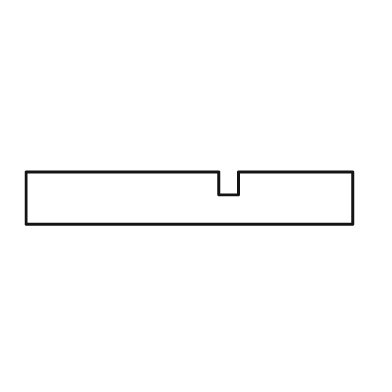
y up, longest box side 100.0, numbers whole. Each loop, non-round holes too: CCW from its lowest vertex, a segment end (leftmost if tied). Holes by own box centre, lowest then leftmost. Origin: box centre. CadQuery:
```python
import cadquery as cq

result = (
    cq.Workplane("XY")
    .moveTo(-50.0, -8.0)
    .lineTo(50.0, -8.0)
    .lineTo(50.0, 8.0)
    .lineTo(15.0, 8.0)
    .lineTo(15.0, 1.0)
    .lineTo(9.0, 1.0)
    .lineTo(9.0, 8.0)
    .lineTo(-50.0, 8.0)
    .close()
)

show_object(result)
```